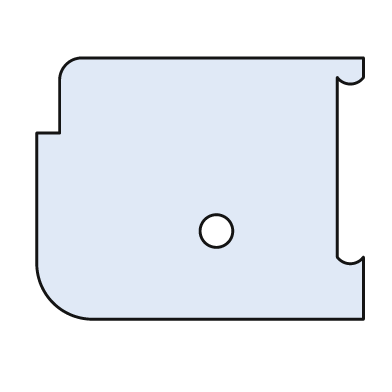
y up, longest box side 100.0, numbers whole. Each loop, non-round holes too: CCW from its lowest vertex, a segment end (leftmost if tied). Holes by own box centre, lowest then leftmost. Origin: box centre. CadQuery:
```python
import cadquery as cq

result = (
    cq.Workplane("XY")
    .moveTo(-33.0, -40.0)
    .lineTo(50.0, -40.0)
    .lineTo(50.0, -21.0)
    .threePointArc((46.0, -23.0), (42.0, -21.0))
    .lineTo(42.0, 34.0)
    .threePointArc((46.0, 32.0), (50.0, 34.0))
    .lineTo(50.0, 40.0)
    .lineTo(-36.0, 40.0)
    .threePointArc((-41.0, 38.0), (-43.0, 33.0))
    .lineTo(-43.0, 17.0)
    .lineTo(-50.0, 17.0)
    .lineTo(-50.0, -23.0)
    .threePointArc((-45.0, -35.0), (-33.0, -40.0))
    .close()
    .moveTo(5.0, -13.0)
    .circle(5.0)
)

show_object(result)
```